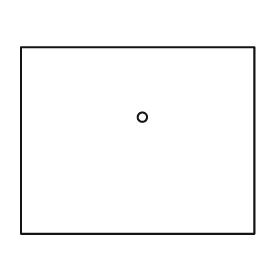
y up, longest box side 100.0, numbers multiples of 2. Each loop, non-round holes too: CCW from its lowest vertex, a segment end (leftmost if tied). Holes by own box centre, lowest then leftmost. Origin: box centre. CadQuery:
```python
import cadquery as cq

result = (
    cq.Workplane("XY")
    .moveTo(-50.0, -40.0)
    .lineTo(50.0, -40.0)
    .lineTo(50.0, 40.0)
    .lineTo(-50.0, 40.0)
    .close()
    .moveTo(2.0, 10.0)
    .circle(2.0)
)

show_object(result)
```